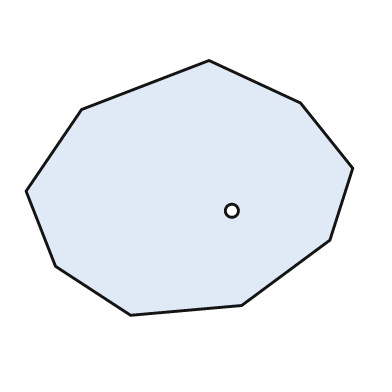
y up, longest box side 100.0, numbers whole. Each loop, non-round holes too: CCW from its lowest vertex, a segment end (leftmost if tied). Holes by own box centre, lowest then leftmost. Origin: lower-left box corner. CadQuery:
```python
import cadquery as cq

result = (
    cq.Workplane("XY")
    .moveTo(32.0, 0.0)
    .lineTo(66.0, 3.0)
    .lineTo(93.0, 23.0)
    .lineTo(100.0, 45.0)
    .lineTo(84.0, 65.0)
    .lineTo(56.0, 78.0)
    .lineTo(17.0, 63.0)
    .lineTo(0.0, 38.0)
    .lineTo(9.0, 15.0)
    .close()
    .moveTo(63.0, 32.0)
    .circle(2.0)
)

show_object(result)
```